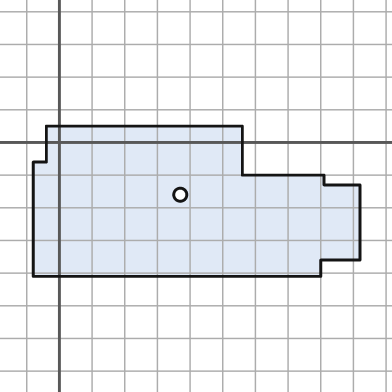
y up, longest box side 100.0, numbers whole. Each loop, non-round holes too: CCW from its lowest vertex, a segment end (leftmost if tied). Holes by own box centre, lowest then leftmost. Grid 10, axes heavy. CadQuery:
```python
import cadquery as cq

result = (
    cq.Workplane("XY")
    .moveTo(-8.0, -41.0)
    .lineTo(80.0, -41.0)
    .lineTo(80.0, -36.0)
    .lineTo(92.0, -36.0)
    .lineTo(92.0, -13.0)
    .lineTo(81.0, -13.0)
    .lineTo(81.0, -10.0)
    .lineTo(56.0, -10.0)
    .lineTo(56.0, 5.0)
    .lineTo(-4.0, 5.0)
    .lineTo(-4.0, -6.0)
    .lineTo(-8.0, -6.0)
    .close()
    .moveTo(37.0, -16.0)
    .circle(2.0)
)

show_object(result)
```